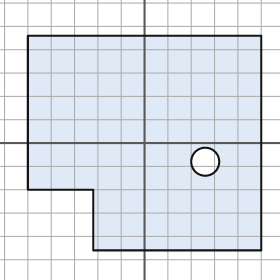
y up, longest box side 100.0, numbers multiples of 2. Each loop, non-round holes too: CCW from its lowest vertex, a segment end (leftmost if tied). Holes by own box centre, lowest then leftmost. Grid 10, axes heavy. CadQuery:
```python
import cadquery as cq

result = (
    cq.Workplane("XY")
    .moveTo(-22.0, -46.0)
    .lineTo(50.0, -46.0)
    .lineTo(50.0, 46.0)
    .lineTo(-50.0, 46.0)
    .lineTo(-50.0, -20.0)
    .lineTo(-22.0, -20.0)
    .close()
    .moveTo(26.0, -8.0)
    .circle(6.0)
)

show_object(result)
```